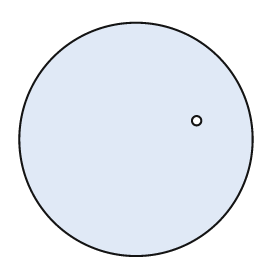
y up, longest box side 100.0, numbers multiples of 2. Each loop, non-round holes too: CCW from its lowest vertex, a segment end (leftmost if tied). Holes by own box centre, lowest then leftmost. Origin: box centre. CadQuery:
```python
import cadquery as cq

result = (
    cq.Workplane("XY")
    .moveTo(0.0, 0.0)
    .circle(50.0)
    .moveTo(26.0, 8.0)
    .circle(2.0)
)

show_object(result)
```